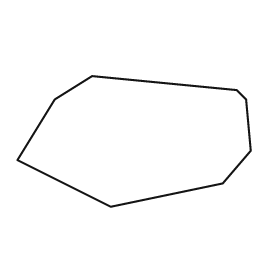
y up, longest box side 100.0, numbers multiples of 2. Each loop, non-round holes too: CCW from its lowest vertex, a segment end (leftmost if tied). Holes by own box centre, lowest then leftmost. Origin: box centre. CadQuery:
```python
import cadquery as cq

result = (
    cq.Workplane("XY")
    .moveTo(-10.0, -28.0)
    .lineTo(38.0, -18.0)
    .lineTo(50.0, -4.0)
    .lineTo(48.0, 18.0)
    .lineTo(44.0, 22.0)
    .lineTo(-18.0, 28.0)
    .lineTo(-34.0, 18.0)
    .lineTo(-50.0, -8.0)
    .close()
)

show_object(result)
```